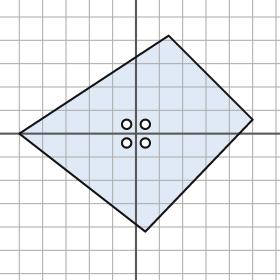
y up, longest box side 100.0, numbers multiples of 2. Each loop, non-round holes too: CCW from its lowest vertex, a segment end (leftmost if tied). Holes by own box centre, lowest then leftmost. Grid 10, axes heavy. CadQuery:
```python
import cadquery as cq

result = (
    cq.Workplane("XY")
    .moveTo(4.0, -42.0)
    .lineTo(50.0, 6.0)
    .lineTo(14.0, 42.0)
    .lineTo(-50.0, 0.0)
    .close()
    .moveTo(-4.0, -4.0)
    .circle(2.0)
    .moveTo(4.0, -4.0)
    .circle(2.0)
    .moveTo(-4.0, 4.0)
    .circle(2.0)
    .moveTo(4.0, 4.0)
    .circle(2.0)
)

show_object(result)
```